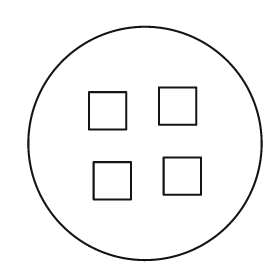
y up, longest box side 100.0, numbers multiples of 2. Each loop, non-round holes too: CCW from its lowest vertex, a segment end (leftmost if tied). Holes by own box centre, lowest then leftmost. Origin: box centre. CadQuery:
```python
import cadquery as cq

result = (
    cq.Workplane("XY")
    .moveTo(0.0, 0.0)
    .circle(50.0)
    .moveTo(-22.0, -24.0)
    .lineTo(-6.0, -24.0)
    .lineTo(-6.0, -8.0)
    .lineTo(-22.0, -8.0)
    .close()
    .moveTo(8.0, -22.0)
    .lineTo(24.0, -22.0)
    .lineTo(24.0, -6.0)
    .lineTo(8.0, -6.0)
    .close()
    .moveTo(-24.0, 6.0)
    .lineTo(-8.0, 6.0)
    .lineTo(-8.0, 22.0)
    .lineTo(-24.0, 22.0)
    .close()
    .moveTo(6.0, 8.0)
    .lineTo(22.0, 8.0)
    .lineTo(22.0, 24.0)
    .lineTo(6.0, 24.0)
    .close()
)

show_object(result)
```